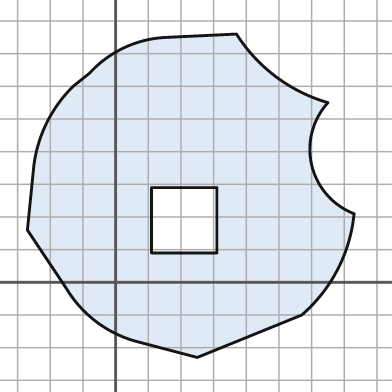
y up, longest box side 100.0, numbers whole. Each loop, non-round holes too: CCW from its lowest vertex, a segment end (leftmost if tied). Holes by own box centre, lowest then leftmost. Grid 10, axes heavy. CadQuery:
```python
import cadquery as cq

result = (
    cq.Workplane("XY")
    .moveTo(25.0, -23.0)
    .lineTo(57.0, -10.0)
    .threePointArc((68.0, 4.0), (73.0, 21.0))
    .threePointArc((60.0, 36.0), (65.0, 55.0))
    .threePointArc((49.0, 63.0), (37.0, 76.0))
    .lineTo(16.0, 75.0)
    .threePointArc((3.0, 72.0), (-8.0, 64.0))
    .lineTo(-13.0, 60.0)
    .threePointArc((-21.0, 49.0), (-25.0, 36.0))
    .lineTo(-27.0, 16.0)
    .lineTo(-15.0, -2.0)
    .threePointArc((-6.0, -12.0), (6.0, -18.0))
    .close()
    .moveTo(11.0, 9.0)
    .lineTo(31.0, 9.0)
    .lineTo(31.0, 29.0)
    .lineTo(11.0, 29.0)
    .close()
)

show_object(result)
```